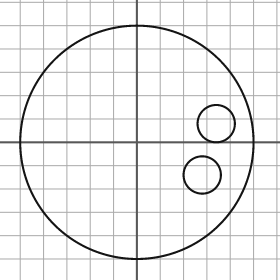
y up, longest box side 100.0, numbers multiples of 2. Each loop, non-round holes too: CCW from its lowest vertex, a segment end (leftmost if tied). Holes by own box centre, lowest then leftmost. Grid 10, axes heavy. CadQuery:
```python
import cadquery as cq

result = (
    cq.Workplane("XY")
    .moveTo(0.0, 0.0)
    .circle(50.0)
    .moveTo(28.0, -14.0)
    .circle(8.0)
    .moveTo(34.0, 8.0)
    .circle(8.0)
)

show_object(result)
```